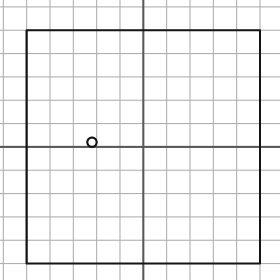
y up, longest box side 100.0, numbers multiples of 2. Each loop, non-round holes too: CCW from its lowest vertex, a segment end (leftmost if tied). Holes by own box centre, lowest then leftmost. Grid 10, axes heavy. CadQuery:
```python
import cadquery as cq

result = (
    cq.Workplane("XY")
    .moveTo(-50.0, -50.0)
    .lineTo(50.0, -50.0)
    .lineTo(50.0, 50.0)
    .lineTo(-50.0, 50.0)
    .close()
    .moveTo(-22.0, 2.0)
    .circle(2.0)
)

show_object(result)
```